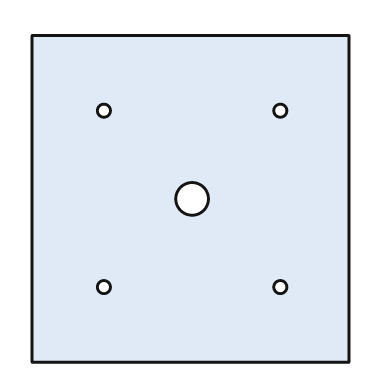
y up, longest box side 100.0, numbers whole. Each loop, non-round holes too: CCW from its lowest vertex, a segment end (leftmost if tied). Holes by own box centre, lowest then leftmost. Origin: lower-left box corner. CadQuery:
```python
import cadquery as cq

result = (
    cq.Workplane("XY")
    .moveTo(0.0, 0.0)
    .lineTo(97.0, 0.0)
    .lineTo(97.0, 100.0)
    .lineTo(0.0, 100.0)
    .close()
    .moveTo(22.0, 23.0)
    .circle(2.0)
    .moveTo(76.0, 23.0)
    .circle(2.0)
    .moveTo(49.0, 50.0)
    .circle(5.0)
    .moveTo(22.0, 77.0)
    .circle(2.0)
    .moveTo(76.0, 77.0)
    .circle(2.0)
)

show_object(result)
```